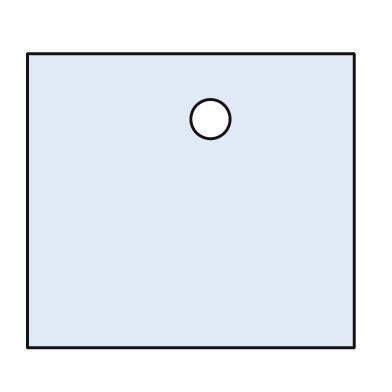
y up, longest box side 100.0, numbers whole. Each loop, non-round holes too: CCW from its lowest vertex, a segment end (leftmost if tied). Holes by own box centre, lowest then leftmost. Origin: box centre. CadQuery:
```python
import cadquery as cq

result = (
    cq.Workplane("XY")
    .moveTo(-50.0, -45.0)
    .lineTo(50.0, -45.0)
    .lineTo(50.0, 45.0)
    .lineTo(-50.0, 45.0)
    .close()
    .moveTo(6.0, 25.0)
    .circle(6.0)
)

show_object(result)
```